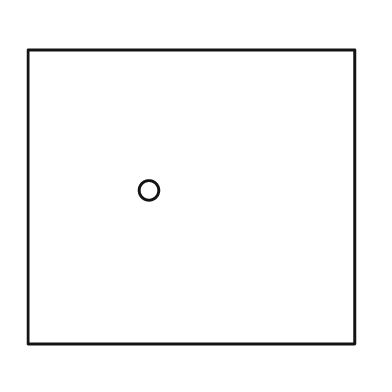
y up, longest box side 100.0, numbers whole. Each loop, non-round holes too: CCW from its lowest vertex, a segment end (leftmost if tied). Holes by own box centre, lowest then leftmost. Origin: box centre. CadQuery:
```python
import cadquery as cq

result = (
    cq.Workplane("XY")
    .moveTo(-50.0, -45.0)
    .lineTo(50.0, -45.0)
    .lineTo(50.0, 45.0)
    .lineTo(-50.0, 45.0)
    .close()
    .moveTo(-13.0, 2.0)
    .circle(3.0)
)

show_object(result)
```